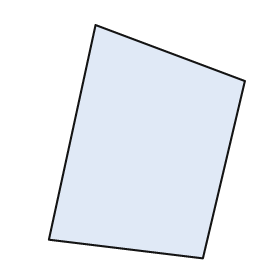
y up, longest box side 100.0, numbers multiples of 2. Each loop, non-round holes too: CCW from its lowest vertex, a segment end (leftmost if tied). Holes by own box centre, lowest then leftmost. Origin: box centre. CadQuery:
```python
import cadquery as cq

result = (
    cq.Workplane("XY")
    .moveTo(24.0, -50.0)
    .lineTo(42.0, 26.0)
    .lineTo(-22.0, 50.0)
    .lineTo(-42.0, -42.0)
    .close()
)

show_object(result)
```